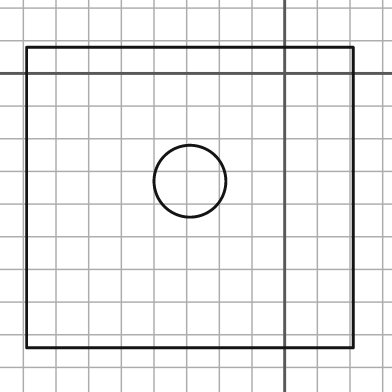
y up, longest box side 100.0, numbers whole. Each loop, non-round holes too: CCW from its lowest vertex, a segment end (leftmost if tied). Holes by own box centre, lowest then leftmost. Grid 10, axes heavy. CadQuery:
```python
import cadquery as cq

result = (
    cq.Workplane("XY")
    .moveTo(-79.0, -84.0)
    .lineTo(21.0, -84.0)
    .lineTo(21.0, 8.0)
    .lineTo(-79.0, 8.0)
    .close()
    .moveTo(-29.0, -33.0)
    .circle(11.0)
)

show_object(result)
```